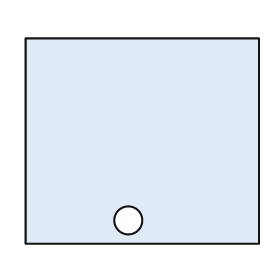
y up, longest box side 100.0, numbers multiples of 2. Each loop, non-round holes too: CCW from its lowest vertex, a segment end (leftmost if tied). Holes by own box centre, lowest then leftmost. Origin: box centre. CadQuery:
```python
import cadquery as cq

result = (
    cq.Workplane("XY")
    .moveTo(-50.0, -44.0)
    .lineTo(50.0, -44.0)
    .lineTo(50.0, 44.0)
    .lineTo(-50.0, 44.0)
    .close()
    .moveTo(-6.0, -34.0)
    .circle(6.0)
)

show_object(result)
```